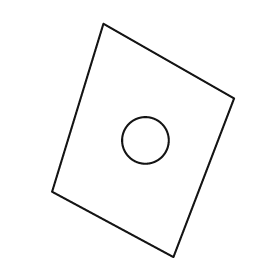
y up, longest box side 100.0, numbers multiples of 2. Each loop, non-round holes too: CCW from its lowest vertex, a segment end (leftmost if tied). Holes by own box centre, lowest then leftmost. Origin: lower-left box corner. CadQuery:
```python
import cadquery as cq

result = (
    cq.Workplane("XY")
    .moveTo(52.0, 0.0)
    .lineTo(78.0, 68.0)
    .lineTo(22.0, 100.0)
    .lineTo(0.0, 28.0)
    .close()
    .moveTo(40.0, 50.0)
    .circle(10.0)
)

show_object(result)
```